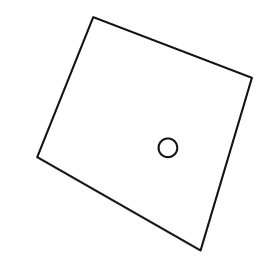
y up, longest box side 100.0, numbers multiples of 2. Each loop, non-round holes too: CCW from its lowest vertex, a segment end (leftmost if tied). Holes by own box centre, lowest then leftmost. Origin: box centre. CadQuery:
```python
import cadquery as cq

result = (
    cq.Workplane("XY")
    .moveTo(24.0, -50.0)
    .lineTo(46.0, 24.0)
    .lineTo(-22.0, 50.0)
    .lineTo(-46.0, -10.0)
    .close()
    .moveTo(10.0, -6.0)
    .circle(4.0)
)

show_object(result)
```